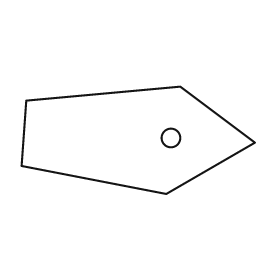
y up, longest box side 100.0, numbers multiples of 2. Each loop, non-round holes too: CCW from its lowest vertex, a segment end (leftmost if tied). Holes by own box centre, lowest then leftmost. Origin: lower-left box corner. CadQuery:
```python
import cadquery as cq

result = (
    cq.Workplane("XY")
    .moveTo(62.0, 0.0)
    .lineTo(100.0, 22.0)
    .lineTo(68.0, 46.0)
    .lineTo(2.0, 40.0)
    .lineTo(0.0, 12.0)
    .close()
    .moveTo(64.0, 24.0)
    .circle(4.0)
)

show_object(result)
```